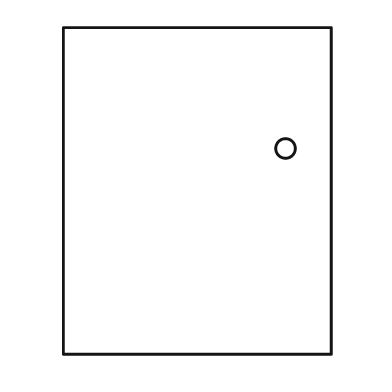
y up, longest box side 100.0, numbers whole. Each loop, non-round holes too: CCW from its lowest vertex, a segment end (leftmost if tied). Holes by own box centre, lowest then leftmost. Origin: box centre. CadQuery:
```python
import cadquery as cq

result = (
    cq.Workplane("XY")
    .moveTo(-41.0, -50.0)
    .lineTo(41.0, -50.0)
    .lineTo(41.0, 50.0)
    .lineTo(-41.0, 50.0)
    .close()
    .moveTo(27.0, 13.0)
    .circle(3.0)
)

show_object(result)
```